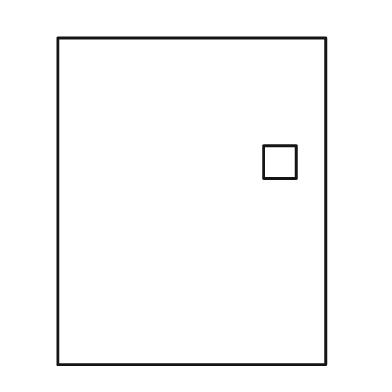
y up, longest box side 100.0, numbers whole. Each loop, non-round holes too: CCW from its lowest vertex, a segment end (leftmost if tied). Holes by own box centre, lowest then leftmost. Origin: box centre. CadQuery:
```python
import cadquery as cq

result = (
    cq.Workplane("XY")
    .moveTo(-41.0, -50.0)
    .lineTo(41.0, -50.0)
    .lineTo(41.0, 50.0)
    .lineTo(-41.0, 50.0)
    .close()
    .moveTo(22.0, 7.0)
    .lineTo(32.0, 7.0)
    .lineTo(32.0, 17.0)
    .lineTo(22.0, 17.0)
    .close()
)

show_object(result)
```